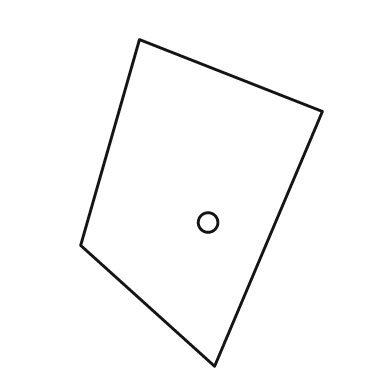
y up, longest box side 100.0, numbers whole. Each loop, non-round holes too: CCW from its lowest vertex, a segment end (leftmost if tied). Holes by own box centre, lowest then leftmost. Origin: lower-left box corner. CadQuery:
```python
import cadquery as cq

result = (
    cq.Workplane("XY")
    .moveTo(41.0, 0.0)
    .lineTo(74.0, 78.0)
    .lineTo(18.0, 100.0)
    .lineTo(0.0, 37.0)
    .close()
    .moveTo(39.0, 44.0)
    .circle(3.0)
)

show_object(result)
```